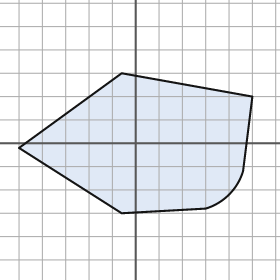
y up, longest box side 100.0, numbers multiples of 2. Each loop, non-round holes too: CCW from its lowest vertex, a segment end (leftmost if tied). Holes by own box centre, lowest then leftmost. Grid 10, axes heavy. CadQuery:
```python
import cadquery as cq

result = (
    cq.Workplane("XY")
    .moveTo(-6.0, -30.0)
    .lineTo(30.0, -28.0)
    .threePointArc((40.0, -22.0), (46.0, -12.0))
    .lineTo(50.0, 20.0)
    .lineTo(-6.0, 30.0)
    .lineTo(-50.0, -2.0)
    .close()
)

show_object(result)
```